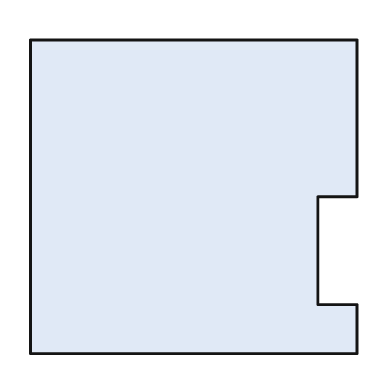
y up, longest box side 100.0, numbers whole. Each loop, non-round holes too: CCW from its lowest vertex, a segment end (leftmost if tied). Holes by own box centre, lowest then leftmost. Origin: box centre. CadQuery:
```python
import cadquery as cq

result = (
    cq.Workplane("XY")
    .moveTo(-50.0, -48.0)
    .lineTo(50.0, -48.0)
    .lineTo(50.0, -33.0)
    .lineTo(38.0, -33.0)
    .lineTo(38.0, 0.0)
    .lineTo(50.0, 0.0)
    .lineTo(50.0, 48.0)
    .lineTo(-50.0, 48.0)
    .close()
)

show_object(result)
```